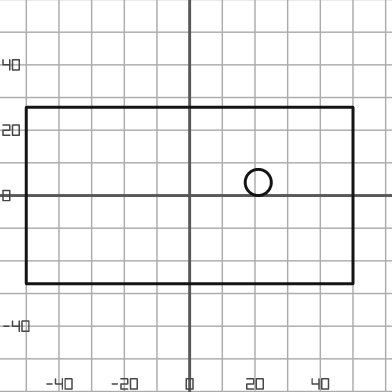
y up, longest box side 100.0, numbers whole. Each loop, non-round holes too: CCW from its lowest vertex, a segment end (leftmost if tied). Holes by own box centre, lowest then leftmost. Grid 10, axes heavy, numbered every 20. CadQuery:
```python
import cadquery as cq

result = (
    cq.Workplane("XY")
    .moveTo(-50.0, -27.0)
    .lineTo(50.0, -27.0)
    .lineTo(50.0, 27.0)
    .lineTo(-50.0, 27.0)
    .close()
    .moveTo(21.0, 4.0)
    .circle(4.0)
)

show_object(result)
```